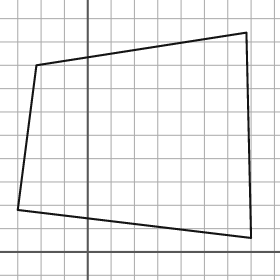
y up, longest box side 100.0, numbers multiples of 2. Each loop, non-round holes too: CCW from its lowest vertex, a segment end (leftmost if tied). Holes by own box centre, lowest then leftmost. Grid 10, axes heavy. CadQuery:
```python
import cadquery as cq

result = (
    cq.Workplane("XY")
    .moveTo(70.0, 6.0)
    .lineTo(68.0, 94.0)
    .lineTo(-22.0, 80.0)
    .lineTo(-30.0, 18.0)
    .close()
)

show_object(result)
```